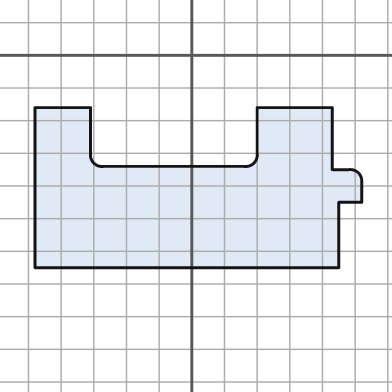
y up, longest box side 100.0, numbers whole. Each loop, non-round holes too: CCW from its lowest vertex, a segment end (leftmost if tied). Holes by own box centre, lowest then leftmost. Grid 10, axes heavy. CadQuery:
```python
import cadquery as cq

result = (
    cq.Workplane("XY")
    .moveTo(-48.0, -65.0)
    .lineTo(45.0, -65.0)
    .lineTo(45.0, -45.0)
    .lineTo(52.0, -45.0)
    .lineTo(52.0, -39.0)
    .threePointArc((51.0, -36.0), (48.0, -35.0))
    .lineTo(43.0, -35.0)
    .lineTo(43.0, -16.0)
    .lineTo(20.0, -16.0)
    .lineTo(20.0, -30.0)
    .threePointArc((19.0, -33.0), (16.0, -34.0))
    .lineTo(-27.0, -34.0)
    .threePointArc((-30.0, -33.0), (-31.0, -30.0))
    .lineTo(-31.0, -16.0)
    .lineTo(-48.0, -16.0)
    .close()
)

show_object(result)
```